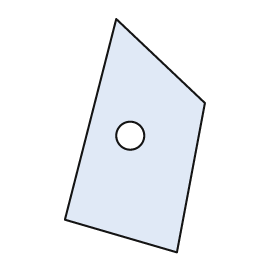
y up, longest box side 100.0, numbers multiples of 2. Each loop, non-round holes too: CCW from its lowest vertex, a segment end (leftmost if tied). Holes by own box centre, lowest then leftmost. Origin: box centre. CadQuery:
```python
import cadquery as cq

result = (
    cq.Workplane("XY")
    .moveTo(18.0, -50.0)
    .lineTo(30.0, 14.0)
    .lineTo(-8.0, 50.0)
    .lineTo(-30.0, -36.0)
    .close()
    .moveTo(-2.0, 0.0)
    .circle(6.0)
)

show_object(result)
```